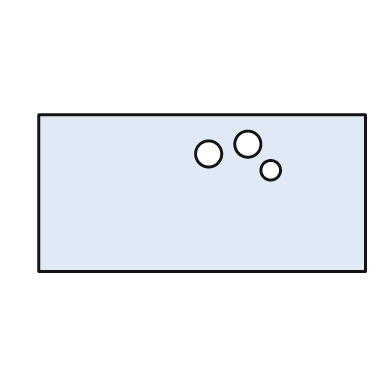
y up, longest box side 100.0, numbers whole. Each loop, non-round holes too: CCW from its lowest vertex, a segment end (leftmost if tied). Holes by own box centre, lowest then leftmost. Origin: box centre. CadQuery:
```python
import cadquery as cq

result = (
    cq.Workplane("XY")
    .moveTo(-50.0, -24.0)
    .lineTo(50.0, -24.0)
    .lineTo(50.0, 24.0)
    .lineTo(-50.0, 24.0)
    .close()
    .moveTo(21.0, 7.0)
    .circle(3.0)
    .moveTo(2.0, 12.0)
    .circle(4.0)
    .moveTo(14.0, 15.0)
    .circle(4.0)
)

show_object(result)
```